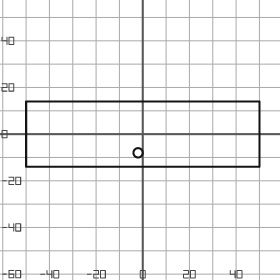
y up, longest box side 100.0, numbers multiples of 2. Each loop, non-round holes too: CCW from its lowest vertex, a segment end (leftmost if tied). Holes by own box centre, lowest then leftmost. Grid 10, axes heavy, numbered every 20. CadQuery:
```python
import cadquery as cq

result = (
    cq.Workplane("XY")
    .moveTo(-50.0, -14.0)
    .lineTo(50.0, -14.0)
    .lineTo(50.0, 14.0)
    .lineTo(-50.0, 14.0)
    .close()
    .moveTo(-2.0, -8.0)
    .circle(2.0)
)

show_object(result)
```